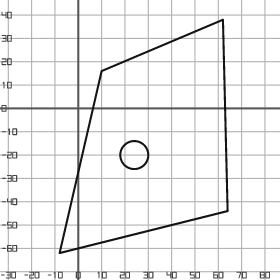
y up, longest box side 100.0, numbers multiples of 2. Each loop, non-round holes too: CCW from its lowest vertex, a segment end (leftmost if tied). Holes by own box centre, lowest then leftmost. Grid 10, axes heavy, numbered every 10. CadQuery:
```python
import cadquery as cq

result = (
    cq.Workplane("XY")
    .moveTo(-8.0, -62.0)
    .lineTo(64.0, -44.0)
    .lineTo(62.0, 38.0)
    .lineTo(10.0, 16.0)
    .close()
    .moveTo(24.0, -20.0)
    .circle(6.0)
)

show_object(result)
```